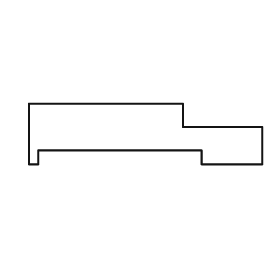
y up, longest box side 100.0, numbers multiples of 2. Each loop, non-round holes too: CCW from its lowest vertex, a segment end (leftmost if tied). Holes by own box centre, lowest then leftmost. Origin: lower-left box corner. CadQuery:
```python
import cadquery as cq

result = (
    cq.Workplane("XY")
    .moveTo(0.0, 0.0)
    .lineTo(4.0, 0.0)
    .lineTo(4.0, 6.0)
    .lineTo(74.0, 6.0)
    .lineTo(74.0, 0.0)
    .lineTo(100.0, 0.0)
    .lineTo(100.0, 16.0)
    .lineTo(66.0, 16.0)
    .lineTo(66.0, 26.0)
    .lineTo(0.0, 26.0)
    .close()
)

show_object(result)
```